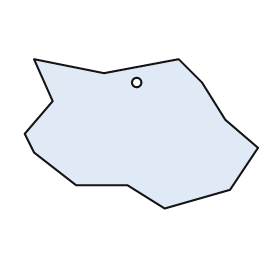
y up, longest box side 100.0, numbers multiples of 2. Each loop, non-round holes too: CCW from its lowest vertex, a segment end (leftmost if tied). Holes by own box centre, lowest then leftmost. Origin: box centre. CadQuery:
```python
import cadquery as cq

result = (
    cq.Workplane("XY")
    .moveTo(10.0, -32.0)
    .lineTo(38.0, -24.0)
    .lineTo(50.0, -6.0)
    .lineTo(36.0, 6.0)
    .lineTo(26.0, 22.0)
    .lineTo(16.0, 32.0)
    .lineTo(-16.0, 26.0)
    .lineTo(-46.0, 32.0)
    .lineTo(-38.0, 14.0)
    .lineTo(-50.0, 0.0)
    .lineTo(-46.0, -8.0)
    .lineTo(-28.0, -22.0)
    .lineTo(-6.0, -22.0)
    .close()
    .moveTo(-2.0, 22.0)
    .circle(2.0)
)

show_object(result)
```